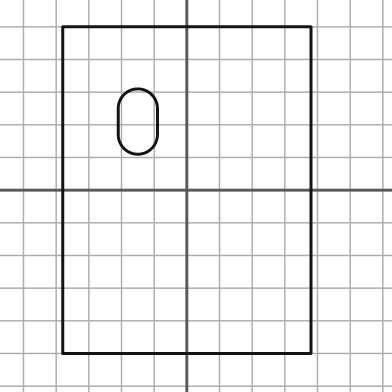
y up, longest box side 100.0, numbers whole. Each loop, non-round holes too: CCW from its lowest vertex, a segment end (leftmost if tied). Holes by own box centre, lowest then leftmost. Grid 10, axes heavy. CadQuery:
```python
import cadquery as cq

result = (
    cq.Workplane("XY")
    .moveTo(-38.0, -50.0)
    .lineTo(38.0, -50.0)
    .lineTo(38.0, 50.0)
    .lineTo(-38.0, 50.0)
    .close()
    .moveTo(-21.0, 17.0)
    .threePointArc((-15.0, 11.0), (-9.0, 17.0))
    .lineTo(-9.0, 25.0)
    .threePointArc((-15.0, 31.0), (-21.0, 25.0))
    .close()
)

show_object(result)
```